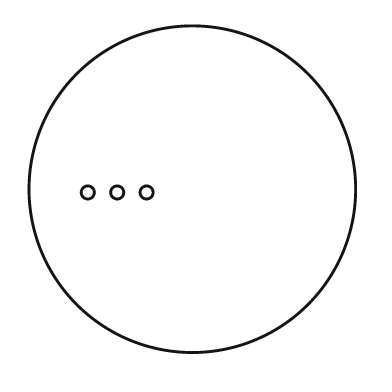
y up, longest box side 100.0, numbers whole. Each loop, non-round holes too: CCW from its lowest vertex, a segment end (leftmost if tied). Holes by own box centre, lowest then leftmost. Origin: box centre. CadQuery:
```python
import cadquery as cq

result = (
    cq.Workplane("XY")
    .moveTo(0.0, 0.0)
    .circle(50.0)
    .moveTo(-32.0, -1.0)
    .circle(2.0)
    .moveTo(-23.0, -1.0)
    .circle(2.0)
    .moveTo(-14.0, -1.0)
    .circle(2.0)
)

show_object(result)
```